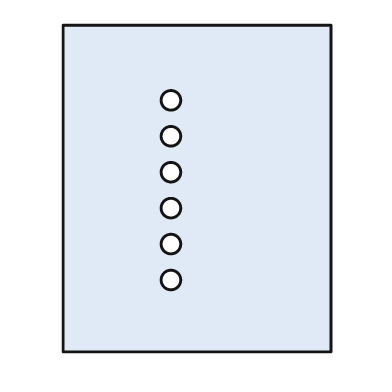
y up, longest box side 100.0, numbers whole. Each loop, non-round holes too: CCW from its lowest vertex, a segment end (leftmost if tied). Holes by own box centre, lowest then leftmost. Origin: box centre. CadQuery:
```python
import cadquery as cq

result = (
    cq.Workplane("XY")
    .moveTo(-41.0, -50.0)
    .lineTo(41.0, -50.0)
    .lineTo(41.0, 50.0)
    .lineTo(-41.0, 50.0)
    .close()
    .moveTo(-8.0, -28.0)
    .circle(3.0)
    .moveTo(-8.0, -17.0)
    .circle(3.0)
    .moveTo(-8.0, -6.0)
    .circle(3.0)
    .moveTo(-8.0, 5.0)
    .circle(3.0)
    .moveTo(-8.0, 16.0)
    .circle(3.0)
    .moveTo(-8.0, 27.0)
    .circle(3.0)
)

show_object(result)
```